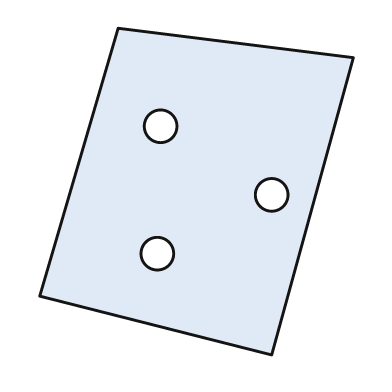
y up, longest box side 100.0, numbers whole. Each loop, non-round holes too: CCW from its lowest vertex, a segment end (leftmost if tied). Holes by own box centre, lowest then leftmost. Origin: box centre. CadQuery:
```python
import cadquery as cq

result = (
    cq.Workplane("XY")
    .moveTo(23.0, -50.0)
    .lineTo(48.0, 41.0)
    .lineTo(-24.0, 50.0)
    .lineTo(-48.0, -32.0)
    .close()
    .moveTo(-12.0, -19.0)
    .circle(5.0)
    .moveTo(23.0, -1.0)
    .circle(5.0)
    .moveTo(-11.0, 20.0)
    .circle(5.0)
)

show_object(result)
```